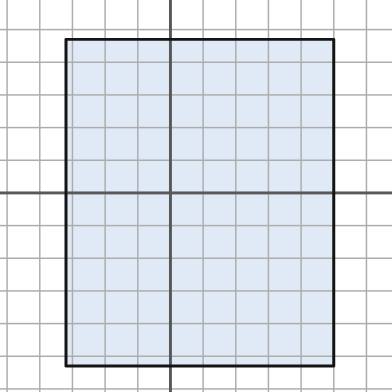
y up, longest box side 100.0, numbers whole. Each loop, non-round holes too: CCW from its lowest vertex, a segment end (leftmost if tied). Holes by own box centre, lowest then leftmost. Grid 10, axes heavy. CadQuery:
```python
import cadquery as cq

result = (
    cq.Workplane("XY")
    .moveTo(-32.0, -53.0)
    .lineTo(50.0, -53.0)
    .lineTo(50.0, 47.0)
    .lineTo(-32.0, 47.0)
    .close()
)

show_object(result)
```